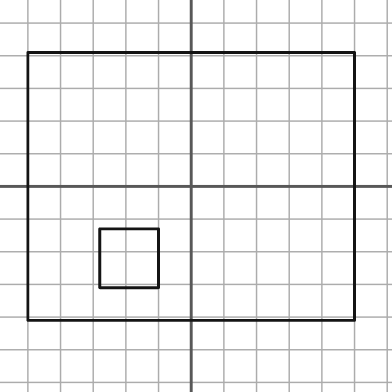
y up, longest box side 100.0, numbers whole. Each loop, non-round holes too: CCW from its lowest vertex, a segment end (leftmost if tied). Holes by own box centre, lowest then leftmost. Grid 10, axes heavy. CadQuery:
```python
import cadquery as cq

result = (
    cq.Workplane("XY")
    .moveTo(-50.0, -41.0)
    .lineTo(50.0, -41.0)
    .lineTo(50.0, 41.0)
    .lineTo(-50.0, 41.0)
    .close()
    .moveTo(-28.0, -31.0)
    .lineTo(-10.0, -31.0)
    .lineTo(-10.0, -13.0)
    .lineTo(-28.0, -13.0)
    .close()
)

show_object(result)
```